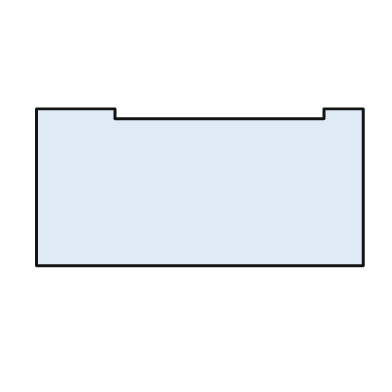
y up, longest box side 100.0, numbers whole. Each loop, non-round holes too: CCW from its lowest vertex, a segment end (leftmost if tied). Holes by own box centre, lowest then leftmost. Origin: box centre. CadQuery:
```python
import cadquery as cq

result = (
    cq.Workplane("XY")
    .moveTo(-50.0, -24.0)
    .lineTo(50.0, -24.0)
    .lineTo(50.0, 24.0)
    .lineTo(38.0, 24.0)
    .lineTo(38.0, 21.0)
    .lineTo(-26.0, 21.0)
    .lineTo(-26.0, 24.0)
    .lineTo(-50.0, 24.0)
    .close()
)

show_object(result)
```